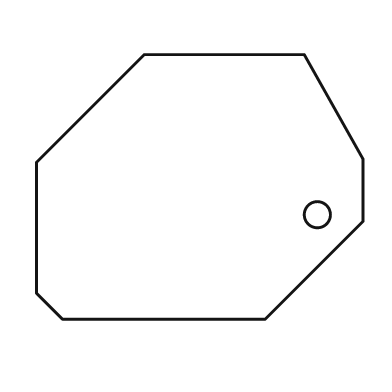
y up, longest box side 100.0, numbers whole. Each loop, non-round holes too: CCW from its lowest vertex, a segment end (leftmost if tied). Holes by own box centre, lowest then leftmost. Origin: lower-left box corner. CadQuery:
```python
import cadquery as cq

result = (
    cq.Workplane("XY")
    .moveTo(8.0, 0.0)
    .lineTo(70.0, 0.0)
    .lineTo(100.0, 30.0)
    .lineTo(100.0, 49.0)
    .lineTo(82.0, 81.0)
    .lineTo(33.0, 81.0)
    .lineTo(0.0, 48.0)
    .lineTo(0.0, 8.0)
    .close()
    .moveTo(86.0, 32.0)
    .circle(4.0)
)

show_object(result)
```